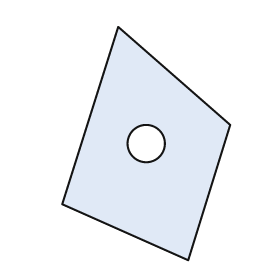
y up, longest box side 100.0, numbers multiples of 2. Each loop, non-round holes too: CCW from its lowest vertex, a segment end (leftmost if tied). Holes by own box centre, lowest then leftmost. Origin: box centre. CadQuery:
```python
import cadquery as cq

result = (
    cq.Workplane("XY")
    .moveTo(18.0, -50.0)
    .lineTo(36.0, 8.0)
    .lineTo(-12.0, 50.0)
    .lineTo(-36.0, -26.0)
    .close()
    .moveTo(0.0, 0.0)
    .circle(8.0)
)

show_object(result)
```